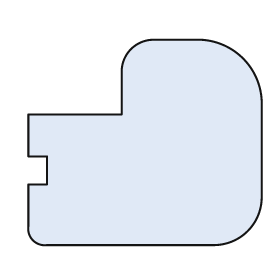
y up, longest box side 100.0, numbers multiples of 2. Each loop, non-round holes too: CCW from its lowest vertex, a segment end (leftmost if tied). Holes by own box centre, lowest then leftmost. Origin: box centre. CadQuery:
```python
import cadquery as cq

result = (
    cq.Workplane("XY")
    .moveTo(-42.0, -44.0)
    .lineTo(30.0, -44.0)
    .threePointArc((44.0, -38.0), (50.0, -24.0))
    .lineTo(50.0, 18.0)
    .threePointArc((42.0, 36.0), (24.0, 44.0))
    .lineTo(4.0, 44.0)
    .threePointArc((-6.0, 40.0), (-10.0, 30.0))
    .lineTo(-10.0, 12.0)
    .lineTo(-50.0, 12.0)
    .lineTo(-50.0, -6.0)
    .lineTo(-42.0, -6.0)
    .lineTo(-42.0, -18.0)
    .lineTo(-50.0, -18.0)
    .lineTo(-50.0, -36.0)
    .threePointArc((-48.0, -42.0), (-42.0, -44.0))
    .close()
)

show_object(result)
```